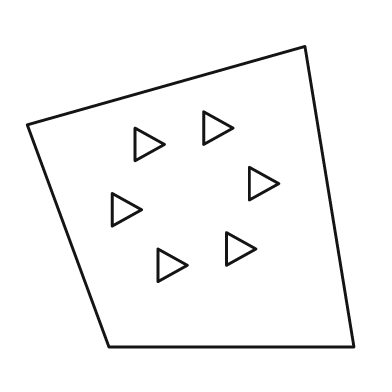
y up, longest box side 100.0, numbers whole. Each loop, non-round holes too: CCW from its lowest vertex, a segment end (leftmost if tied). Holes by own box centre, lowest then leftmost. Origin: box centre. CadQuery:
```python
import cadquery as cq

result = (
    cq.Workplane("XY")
    .moveTo(-25.0, -46.0)
    .lineTo(50.0, -46.0)
    .lineTo(35.0, 46.0)
    .lineTo(-50.0, 22.0)
    .close()
    .moveTo(-10.0, -26.0)
    .lineTo(-1.0, -21.0)
    .lineTo(-10.0, -16.0)
    .close()
    .moveTo(11.0, -21.0)
    .lineTo(20.0, -16.0)
    .lineTo(11.0, -11.0)
    .close()
    .moveTo(-24.0, -9.0)
    .lineTo(-15.0, -4.0)
    .lineTo(-24.0, 1.0)
    .close()
    .moveTo(18.0, -1.0)
    .lineTo(27.0, 4.0)
    .lineTo(18.0, 9.0)
    .close()
    .moveTo(-17.0, 11.0)
    .lineTo(-8.0, 16.0)
    .lineTo(-17.0, 21.0)
    .close()
    .moveTo(4.0, 16.0)
    .lineTo(13.0, 21.0)
    .lineTo(4.0, 26.0)
    .close()
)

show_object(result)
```